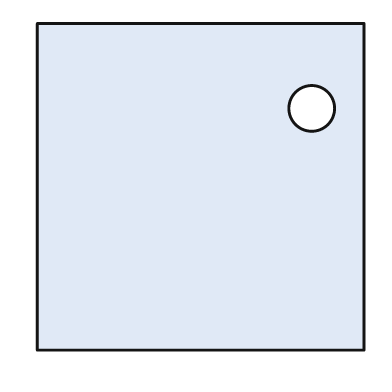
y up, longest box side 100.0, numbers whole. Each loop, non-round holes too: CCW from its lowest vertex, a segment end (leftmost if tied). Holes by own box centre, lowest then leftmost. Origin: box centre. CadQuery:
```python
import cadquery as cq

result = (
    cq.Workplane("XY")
    .moveTo(-50.0, -50.0)
    .lineTo(50.0, -50.0)
    .lineTo(50.0, 50.0)
    .lineTo(-50.0, 50.0)
    .close()
    .moveTo(34.0, 24.0)
    .circle(7.0)
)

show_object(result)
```